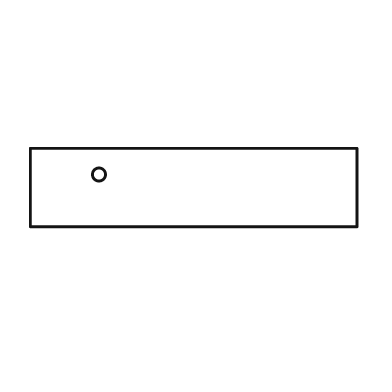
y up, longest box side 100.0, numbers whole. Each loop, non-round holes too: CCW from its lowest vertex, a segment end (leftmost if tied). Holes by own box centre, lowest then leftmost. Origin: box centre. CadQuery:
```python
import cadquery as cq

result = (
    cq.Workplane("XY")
    .moveTo(-50.0, -12.0)
    .lineTo(50.0, -12.0)
    .lineTo(50.0, 12.0)
    .lineTo(-50.0, 12.0)
    .close()
    .moveTo(-29.0, 4.0)
    .circle(2.0)
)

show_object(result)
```